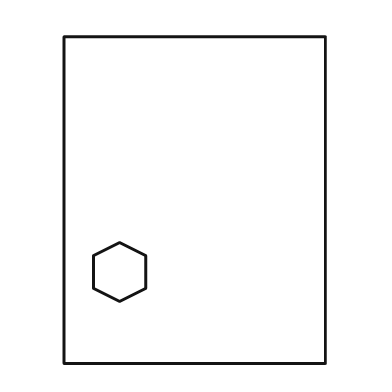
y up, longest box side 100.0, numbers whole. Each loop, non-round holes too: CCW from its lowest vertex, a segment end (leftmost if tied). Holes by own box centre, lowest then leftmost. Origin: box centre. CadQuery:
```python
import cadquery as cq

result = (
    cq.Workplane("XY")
    .moveTo(-40.0, -50.0)
    .lineTo(40.0, -50.0)
    .lineTo(40.0, 50.0)
    .lineTo(-40.0, 50.0)
    .close()
    .moveTo(-23.0, -31.0)
    .lineTo(-15.0, -27.0)
    .lineTo(-15.0, -17.0)
    .lineTo(-23.0, -13.0)
    .lineTo(-31.0, -17.0)
    .lineTo(-31.0, -27.0)
    .close()
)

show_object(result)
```